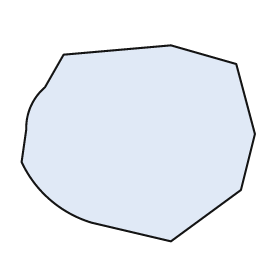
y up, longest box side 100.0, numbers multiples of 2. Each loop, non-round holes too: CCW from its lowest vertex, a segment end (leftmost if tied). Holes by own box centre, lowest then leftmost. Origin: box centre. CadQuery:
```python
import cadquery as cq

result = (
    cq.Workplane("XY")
    .moveTo(14.0, -42.0)
    .lineTo(44.0, -20.0)
    .lineTo(50.0, 4.0)
    .lineTo(42.0, 34.0)
    .lineTo(14.0, 42.0)
    .lineTo(-32.0, 38.0)
    .lineTo(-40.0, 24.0)
    .threePointArc((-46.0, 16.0), (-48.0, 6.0))
    .lineTo(-50.0, -8.0)
    .threePointArc((-38.0, -24.0), (-20.0, -34.0))
    .close()
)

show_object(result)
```